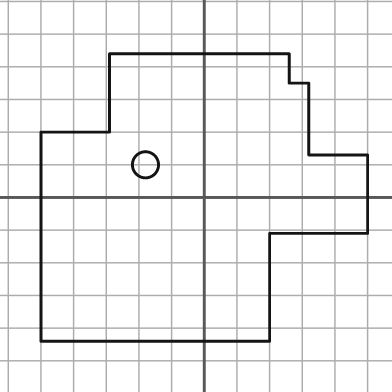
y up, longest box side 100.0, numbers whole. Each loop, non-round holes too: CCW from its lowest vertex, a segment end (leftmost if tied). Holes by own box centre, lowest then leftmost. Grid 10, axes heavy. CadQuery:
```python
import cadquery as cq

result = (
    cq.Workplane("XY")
    .moveTo(-50.0, -44.0)
    .lineTo(20.0, -44.0)
    .lineTo(20.0, -11.0)
    .lineTo(50.0, -11.0)
    .lineTo(50.0, 13.0)
    .lineTo(32.0, 13.0)
    .lineTo(32.0, 35.0)
    .lineTo(26.0, 35.0)
    .lineTo(26.0, 44.0)
    .lineTo(-29.0, 44.0)
    .lineTo(-29.0, 20.0)
    .lineTo(-50.0, 20.0)
    .close()
    .moveTo(-18.0, 10.0)
    .circle(4.0)
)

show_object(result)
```